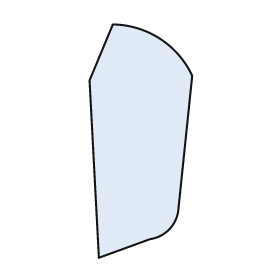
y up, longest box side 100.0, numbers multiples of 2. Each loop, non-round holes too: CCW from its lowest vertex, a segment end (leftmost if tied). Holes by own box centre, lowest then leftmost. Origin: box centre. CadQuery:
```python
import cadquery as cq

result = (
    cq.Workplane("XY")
    .moveTo(-18.0, -50.0)
    .lineTo(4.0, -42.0)
    .threePointArc((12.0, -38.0), (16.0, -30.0))
    .lineTo(22.0, 28.0)
    .threePointArc((8.0, 44.0), (-12.0, 50.0))
    .lineTo(-22.0, 26.0)
    .close()
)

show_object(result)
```